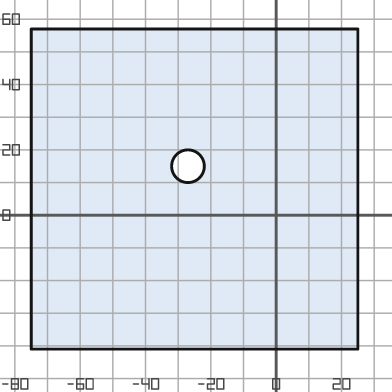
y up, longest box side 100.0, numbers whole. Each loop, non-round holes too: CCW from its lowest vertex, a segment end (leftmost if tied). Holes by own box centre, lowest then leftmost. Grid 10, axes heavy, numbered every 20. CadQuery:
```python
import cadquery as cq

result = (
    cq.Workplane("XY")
    .moveTo(-75.0, -41.0)
    .lineTo(25.0, -41.0)
    .lineTo(25.0, 57.0)
    .lineTo(-75.0, 57.0)
    .close()
    .moveTo(-27.0, 15.0)
    .circle(5.0)
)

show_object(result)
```